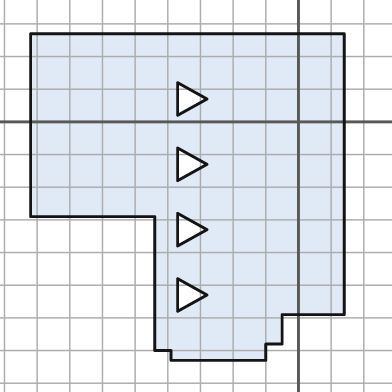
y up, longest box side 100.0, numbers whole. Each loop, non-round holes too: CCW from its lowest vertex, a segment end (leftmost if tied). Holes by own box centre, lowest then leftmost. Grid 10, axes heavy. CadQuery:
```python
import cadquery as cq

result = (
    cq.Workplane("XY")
    .moveTo(-39.0, -73.0)
    .lineTo(-10.0, -73.0)
    .lineTo(-10.0, -68.0)
    .lineTo(-5.0, -68.0)
    .lineTo(-5.0, -59.0)
    .lineTo(14.0, -59.0)
    .lineTo(14.0, 27.0)
    .lineTo(-82.0, 27.0)
    .lineTo(-82.0, -29.0)
    .lineTo(-44.0, -29.0)
    .lineTo(-44.0, -70.0)
    .lineTo(-39.0, -70.0)
    .close()
    .moveTo(-37.0, -58.0)
    .lineTo(-28.0, -53.0)
    .lineTo(-37.0, -48.0)
    .close()
    .moveTo(-37.0, -38.0)
    .lineTo(-28.0, -33.0)
    .lineTo(-37.0, -28.0)
    .close()
    .moveTo(-37.0, -18.0)
    .lineTo(-28.0, -13.0)
    .lineTo(-37.0, -8.0)
    .close()
    .moveTo(-37.0, 2.0)
    .lineTo(-28.0, 7.0)
    .lineTo(-37.0, 12.0)
    .close()
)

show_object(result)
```